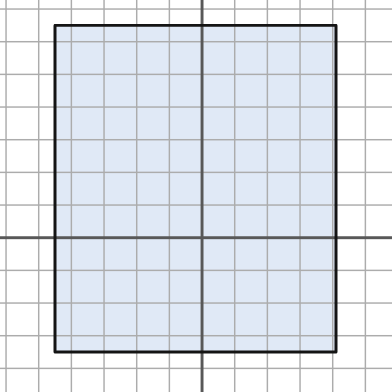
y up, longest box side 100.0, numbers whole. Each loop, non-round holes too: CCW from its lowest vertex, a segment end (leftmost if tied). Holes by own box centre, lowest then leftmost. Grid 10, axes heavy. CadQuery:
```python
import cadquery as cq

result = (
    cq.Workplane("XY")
    .moveTo(-45.0, -35.0)
    .lineTo(41.0, -35.0)
    .lineTo(41.0, 65.0)
    .lineTo(-45.0, 65.0)
    .close()
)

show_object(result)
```